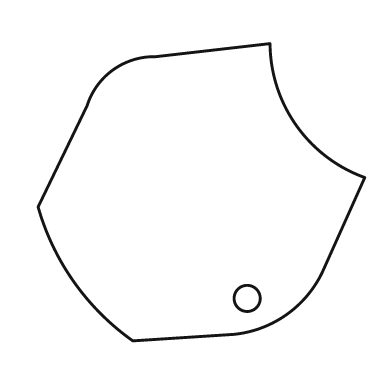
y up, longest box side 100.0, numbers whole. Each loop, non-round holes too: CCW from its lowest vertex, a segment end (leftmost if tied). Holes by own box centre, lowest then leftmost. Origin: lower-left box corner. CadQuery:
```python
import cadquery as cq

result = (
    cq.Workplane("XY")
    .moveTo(29.0, 0.0)
    .lineTo(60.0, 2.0)
    .threePointArc((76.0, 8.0), (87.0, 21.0))
    .lineTo(100.0, 50.0)
    .threePointArc((79.0, 66.0), (71.0, 91.0))
    .lineTo(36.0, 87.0)
    .threePointArc((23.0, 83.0), (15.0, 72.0))
    .lineTo(0.0, 41.0)
    .threePointArc((11.0, 18.0), (29.0, 0.0))
    .close()
    .moveTo(64.0, 13.0)
    .circle(4.0)
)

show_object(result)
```